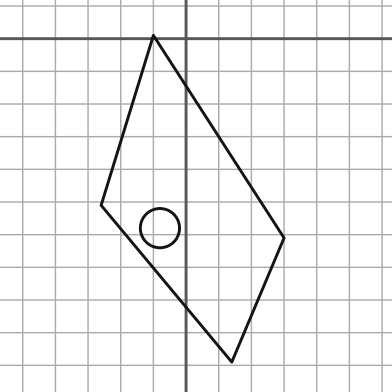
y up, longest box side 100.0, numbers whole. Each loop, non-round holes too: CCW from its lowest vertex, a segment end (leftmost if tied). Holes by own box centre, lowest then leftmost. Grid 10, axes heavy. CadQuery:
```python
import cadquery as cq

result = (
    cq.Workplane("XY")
    .moveTo(14.0, -99.0)
    .lineTo(30.0, -61.0)
    .lineTo(-10.0, 1.0)
    .lineTo(-26.0, -51.0)
    .close()
    .moveTo(-8.0, -58.0)
    .circle(6.0)
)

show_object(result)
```